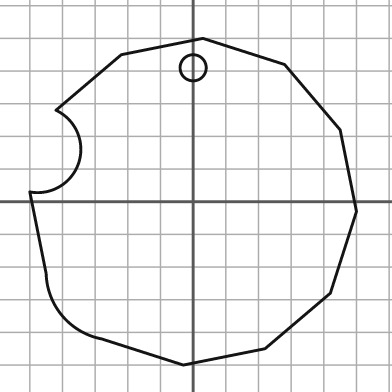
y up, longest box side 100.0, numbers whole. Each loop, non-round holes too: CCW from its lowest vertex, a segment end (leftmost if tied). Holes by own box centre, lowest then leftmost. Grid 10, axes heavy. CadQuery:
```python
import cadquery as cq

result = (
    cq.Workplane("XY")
    .moveTo(-3.0, -50.0)
    .lineTo(22.0, -45.0)
    .lineTo(42.0, -28.0)
    .lineTo(50.0, -3.0)
    .lineTo(45.0, 22.0)
    .lineTo(28.0, 42.0)
    .lineTo(3.0, 50.0)
    .lineTo(-22.0, 45.0)
    .lineTo(-42.0, 28.0)
    .threePointArc((-35.0, 12.0), (-50.0, 3.0))
    .lineTo(-45.0, -22.0)
    .threePointArc((-40.0, -35.0), (-28.0, -42.0))
    .close()
    .moveTo(0.0, 41.0)
    .circle(4.0)
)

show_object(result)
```